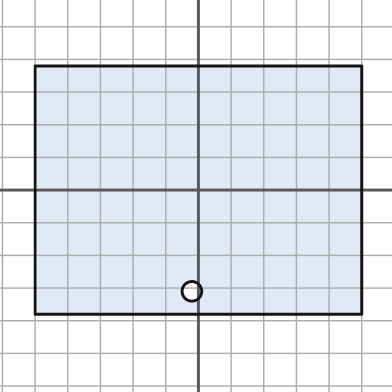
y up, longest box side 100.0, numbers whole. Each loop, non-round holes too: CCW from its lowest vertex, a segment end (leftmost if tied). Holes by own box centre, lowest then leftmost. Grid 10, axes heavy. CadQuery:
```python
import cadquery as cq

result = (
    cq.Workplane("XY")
    .moveTo(-50.0, -38.0)
    .lineTo(50.0, -38.0)
    .lineTo(50.0, 38.0)
    .lineTo(-50.0, 38.0)
    .close()
    .moveTo(-2.0, -31.0)
    .circle(3.0)
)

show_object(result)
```